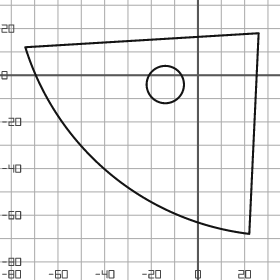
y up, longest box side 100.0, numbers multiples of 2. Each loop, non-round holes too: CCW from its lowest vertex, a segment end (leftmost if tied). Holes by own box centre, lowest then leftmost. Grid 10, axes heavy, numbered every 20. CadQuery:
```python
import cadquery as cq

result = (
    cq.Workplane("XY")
    .moveTo(22.0, -68.0)
    .lineTo(26.0, 18.0)
    .lineTo(-74.0, 12.0)
    .threePointArc((-38.0, -42.0), (22.0, -68.0))
    .close()
    .moveTo(-14.0, -4.0)
    .circle(8.0)
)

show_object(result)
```